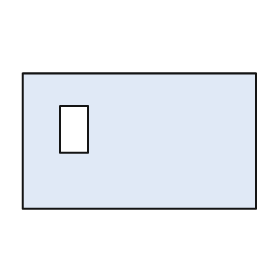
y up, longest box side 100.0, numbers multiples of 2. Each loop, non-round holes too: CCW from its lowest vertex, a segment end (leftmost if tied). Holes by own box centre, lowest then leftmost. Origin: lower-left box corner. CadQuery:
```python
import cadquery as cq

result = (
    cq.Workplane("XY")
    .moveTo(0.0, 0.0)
    .lineTo(100.0, 0.0)
    .lineTo(100.0, 58.0)
    .lineTo(0.0, 58.0)
    .close()
    .moveTo(16.0, 24.0)
    .lineTo(28.0, 24.0)
    .lineTo(28.0, 44.0)
    .lineTo(16.0, 44.0)
    .close()
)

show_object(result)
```